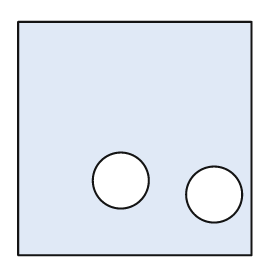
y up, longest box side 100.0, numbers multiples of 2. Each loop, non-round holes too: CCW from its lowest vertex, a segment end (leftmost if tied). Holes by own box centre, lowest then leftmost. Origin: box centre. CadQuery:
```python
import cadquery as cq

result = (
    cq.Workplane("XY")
    .moveTo(-50.0, -50.0)
    .lineTo(50.0, -50.0)
    .lineTo(50.0, 50.0)
    .lineTo(-50.0, 50.0)
    .close()
    .moveTo(34.0, -24.0)
    .circle(12.0)
    .moveTo(-6.0, -18.0)
    .circle(12.0)
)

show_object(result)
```